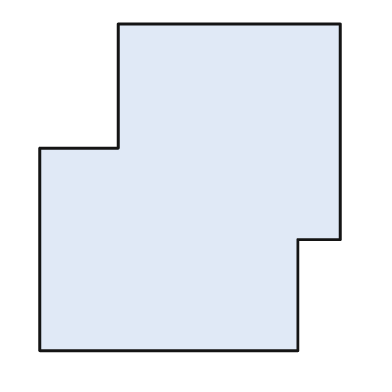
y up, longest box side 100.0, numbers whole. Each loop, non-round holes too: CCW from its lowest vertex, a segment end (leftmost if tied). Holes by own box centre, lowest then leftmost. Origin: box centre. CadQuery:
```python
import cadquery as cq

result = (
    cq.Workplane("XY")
    .moveTo(-46.0, -50.0)
    .lineTo(33.0, -50.0)
    .lineTo(33.0, -16.0)
    .lineTo(46.0, -16.0)
    .lineTo(46.0, 50.0)
    .lineTo(-22.0, 50.0)
    .lineTo(-22.0, 12.0)
    .lineTo(-46.0, 12.0)
    .close()
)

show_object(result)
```